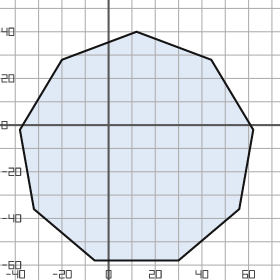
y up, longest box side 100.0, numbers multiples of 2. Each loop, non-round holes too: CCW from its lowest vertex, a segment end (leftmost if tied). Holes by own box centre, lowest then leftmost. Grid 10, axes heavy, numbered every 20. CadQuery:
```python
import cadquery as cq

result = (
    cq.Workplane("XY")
    .moveTo(-6.0, -58.0)
    .lineTo(30.0, -58.0)
    .lineTo(56.0, -36.0)
    .lineTo(62.0, -2.0)
    .lineTo(44.0, 28.0)
    .lineTo(12.0, 40.0)
    .lineTo(-20.0, 28.0)
    .lineTo(-38.0, -2.0)
    .lineTo(-32.0, -36.0)
    .close()
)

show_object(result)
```